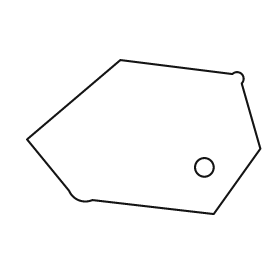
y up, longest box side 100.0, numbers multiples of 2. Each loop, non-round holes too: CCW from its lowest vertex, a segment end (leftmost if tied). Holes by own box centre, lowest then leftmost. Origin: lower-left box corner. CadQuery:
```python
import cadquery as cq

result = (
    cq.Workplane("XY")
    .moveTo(80.0, 0.0)
    .lineTo(100.0, 28.0)
    .lineTo(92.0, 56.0)
    .threePointArc((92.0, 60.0), (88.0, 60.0))
    .lineTo(40.0, 66.0)
    .lineTo(0.0, 32.0)
    .lineTo(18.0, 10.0)
    .threePointArc((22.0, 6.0), (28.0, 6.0))
    .close()
    .moveTo(76.0, 20.0)
    .circle(4.0)
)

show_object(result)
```